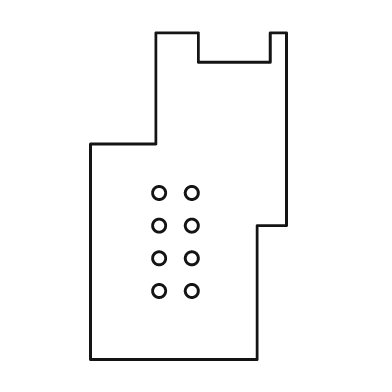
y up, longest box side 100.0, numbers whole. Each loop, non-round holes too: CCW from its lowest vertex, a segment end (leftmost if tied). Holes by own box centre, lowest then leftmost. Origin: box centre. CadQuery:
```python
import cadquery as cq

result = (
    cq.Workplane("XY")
    .moveTo(-30.0, -50.0)
    .lineTo(21.0, -50.0)
    .lineTo(21.0, -9.0)
    .lineTo(30.0, -9.0)
    .lineTo(30.0, 50.0)
    .lineTo(25.0, 50.0)
    .lineTo(25.0, 41.0)
    .lineTo(3.0, 41.0)
    .lineTo(3.0, 50.0)
    .lineTo(-10.0, 50.0)
    .lineTo(-10.0, 16.0)
    .lineTo(-30.0, 16.0)
    .close()
    .moveTo(-9.0, -29.0)
    .circle(2.0)
    .moveTo(1.0, -29.0)
    .circle(2.0)
    .moveTo(-9.0, -19.0)
    .circle(2.0)
    .moveTo(1.0, -19.0)
    .circle(2.0)
    .moveTo(-9.0, -9.0)
    .circle(2.0)
    .moveTo(1.0, -9.0)
    .circle(2.0)
    .moveTo(-9.0, 1.0)
    .circle(2.0)
    .moveTo(1.0, 1.0)
    .circle(2.0)
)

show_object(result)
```